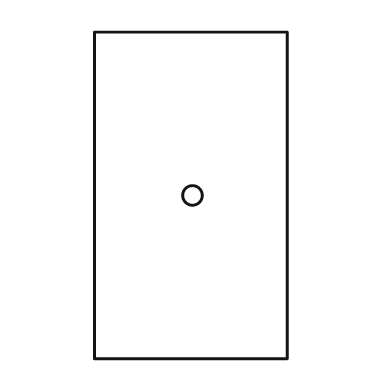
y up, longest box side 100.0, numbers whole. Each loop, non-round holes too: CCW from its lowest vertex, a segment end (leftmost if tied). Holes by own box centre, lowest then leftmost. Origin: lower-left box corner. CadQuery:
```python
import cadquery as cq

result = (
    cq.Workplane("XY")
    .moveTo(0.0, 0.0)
    .lineTo(59.0, 0.0)
    .lineTo(59.0, 100.0)
    .lineTo(0.0, 100.0)
    .close()
    .moveTo(30.0, 50.0)
    .circle(3.0)
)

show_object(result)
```